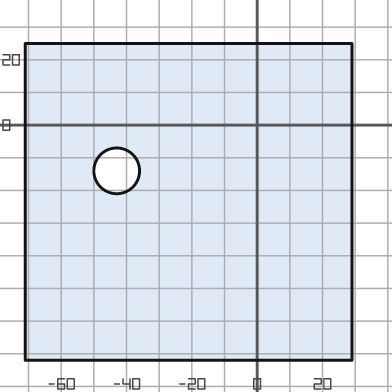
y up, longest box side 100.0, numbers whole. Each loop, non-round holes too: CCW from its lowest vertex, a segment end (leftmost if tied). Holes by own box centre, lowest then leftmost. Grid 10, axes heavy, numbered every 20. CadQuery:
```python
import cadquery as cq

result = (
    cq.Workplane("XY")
    .moveTo(-71.0, -72.0)
    .lineTo(29.0, -72.0)
    .lineTo(29.0, 25.0)
    .lineTo(-71.0, 25.0)
    .close()
    .moveTo(-43.0, -14.0)
    .circle(7.0)
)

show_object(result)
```